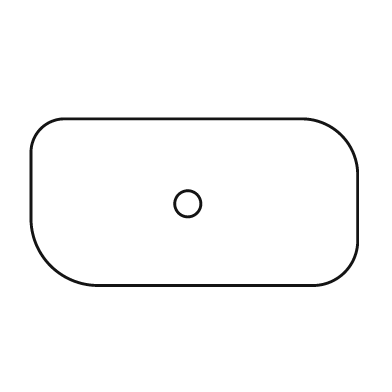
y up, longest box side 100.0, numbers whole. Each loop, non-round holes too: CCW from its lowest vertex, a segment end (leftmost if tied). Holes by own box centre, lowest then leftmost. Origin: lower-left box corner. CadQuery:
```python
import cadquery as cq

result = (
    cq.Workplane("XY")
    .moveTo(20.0, 0.0)
    .lineTo(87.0, 0.0)
    .threePointArc((96.0, 4.0), (100.0, 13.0))
    .lineTo(100.0, 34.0)
    .threePointArc((95.0, 46.0), (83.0, 51.0))
    .lineTo(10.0, 51.0)
    .threePointArc((3.0, 48.0), (0.0, 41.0))
    .lineTo(0.0, 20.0)
    .threePointArc((6.0, 6.0), (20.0, 0.0))
    .close()
    .moveTo(48.0, 25.0)
    .circle(4.0)
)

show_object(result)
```